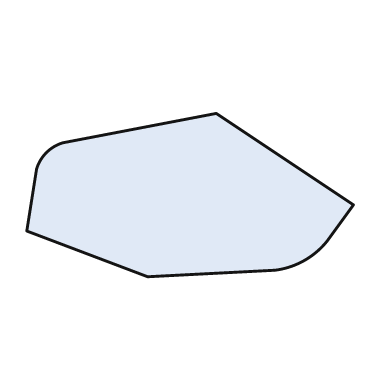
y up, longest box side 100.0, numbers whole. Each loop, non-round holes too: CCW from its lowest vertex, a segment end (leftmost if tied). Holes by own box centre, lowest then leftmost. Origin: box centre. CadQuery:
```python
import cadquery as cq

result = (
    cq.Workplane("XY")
    .moveTo(-13.0, -25.0)
    .lineTo(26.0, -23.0)
    .threePointArc((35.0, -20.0), (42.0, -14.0))
    .lineTo(50.0, -3.0)
    .lineTo(8.0, 25.0)
    .lineTo(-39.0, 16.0)
    .threePointArc((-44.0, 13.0), (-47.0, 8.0))
    .lineTo(-50.0, -11.0)
    .close()
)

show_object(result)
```